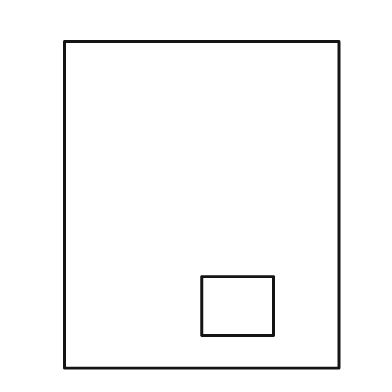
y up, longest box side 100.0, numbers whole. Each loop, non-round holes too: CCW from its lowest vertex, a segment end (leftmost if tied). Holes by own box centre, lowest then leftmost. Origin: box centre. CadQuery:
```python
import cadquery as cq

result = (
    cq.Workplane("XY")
    .moveTo(-42.0, -50.0)
    .lineTo(42.0, -50.0)
    .lineTo(42.0, 50.0)
    .lineTo(-42.0, 50.0)
    .close()
    .moveTo(0.0, -40.0)
    .lineTo(22.0, -40.0)
    .lineTo(22.0, -22.0)
    .lineTo(0.0, -22.0)
    .close()
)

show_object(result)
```